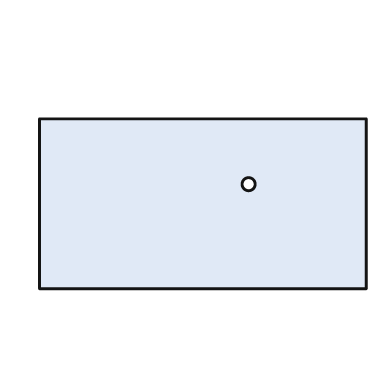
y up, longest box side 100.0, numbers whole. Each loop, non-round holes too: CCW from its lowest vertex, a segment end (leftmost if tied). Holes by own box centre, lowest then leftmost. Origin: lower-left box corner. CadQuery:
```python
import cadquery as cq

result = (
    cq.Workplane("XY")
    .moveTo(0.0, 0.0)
    .lineTo(100.0, 0.0)
    .lineTo(100.0, 52.0)
    .lineTo(0.0, 52.0)
    .close()
    .moveTo(64.0, 32.0)
    .circle(2.0)
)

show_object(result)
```